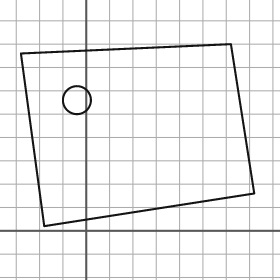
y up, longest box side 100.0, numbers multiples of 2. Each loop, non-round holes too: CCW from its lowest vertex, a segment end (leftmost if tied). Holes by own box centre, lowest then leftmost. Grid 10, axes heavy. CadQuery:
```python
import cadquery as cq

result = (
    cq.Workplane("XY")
    .moveTo(-18.0, 2.0)
    .lineTo(72.0, 16.0)
    .lineTo(62.0, 80.0)
    .lineTo(-28.0, 76.0)
    .close()
    .moveTo(-4.0, 56.0)
    .circle(6.0)
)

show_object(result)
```